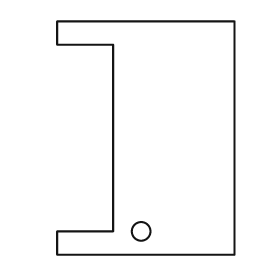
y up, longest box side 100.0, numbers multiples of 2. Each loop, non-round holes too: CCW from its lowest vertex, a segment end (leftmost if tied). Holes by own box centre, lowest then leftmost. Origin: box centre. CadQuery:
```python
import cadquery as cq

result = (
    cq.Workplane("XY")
    .moveTo(-38.0, -50.0)
    .lineTo(38.0, -50.0)
    .lineTo(38.0, 50.0)
    .lineTo(-38.0, 50.0)
    .lineTo(-38.0, 40.0)
    .lineTo(-14.0, 40.0)
    .lineTo(-14.0, -40.0)
    .lineTo(-38.0, -40.0)
    .close()
    .moveTo(-2.0, -40.0)
    .circle(4.0)
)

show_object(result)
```